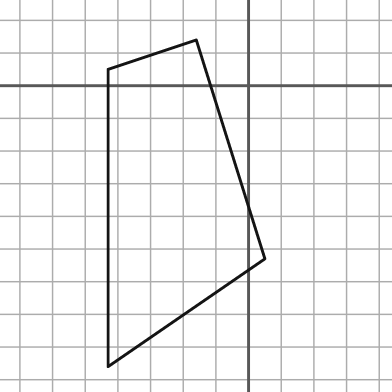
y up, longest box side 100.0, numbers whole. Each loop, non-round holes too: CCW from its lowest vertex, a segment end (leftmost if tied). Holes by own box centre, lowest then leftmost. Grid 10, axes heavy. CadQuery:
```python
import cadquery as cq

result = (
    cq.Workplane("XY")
    .moveTo(-43.0, -86.0)
    .lineTo(5.0, -53.0)
    .lineTo(-16.0, 14.0)
    .lineTo(-43.0, 5.0)
    .close()
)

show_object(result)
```